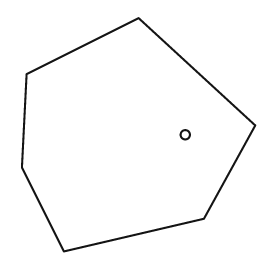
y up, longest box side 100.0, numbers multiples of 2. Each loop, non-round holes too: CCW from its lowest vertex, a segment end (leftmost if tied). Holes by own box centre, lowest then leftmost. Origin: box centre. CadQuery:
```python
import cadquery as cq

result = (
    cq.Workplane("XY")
    .moveTo(-32.0, -50.0)
    .lineTo(28.0, -36.0)
    .lineTo(50.0, 4.0)
    .lineTo(0.0, 50.0)
    .lineTo(-48.0, 26.0)
    .lineTo(-50.0, -14.0)
    .close()
    .moveTo(20.0, 0.0)
    .circle(2.0)
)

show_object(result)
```